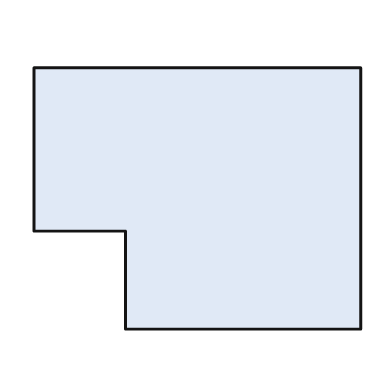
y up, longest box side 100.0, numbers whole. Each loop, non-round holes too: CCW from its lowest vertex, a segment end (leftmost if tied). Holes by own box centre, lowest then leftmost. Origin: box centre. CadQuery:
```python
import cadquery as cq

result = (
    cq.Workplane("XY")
    .moveTo(-22.0, -40.0)
    .lineTo(50.0, -40.0)
    .lineTo(50.0, 40.0)
    .lineTo(-50.0, 40.0)
    .lineTo(-50.0, -10.0)
    .lineTo(-22.0, -10.0)
    .close()
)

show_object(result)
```